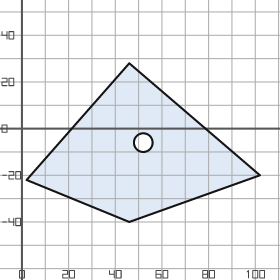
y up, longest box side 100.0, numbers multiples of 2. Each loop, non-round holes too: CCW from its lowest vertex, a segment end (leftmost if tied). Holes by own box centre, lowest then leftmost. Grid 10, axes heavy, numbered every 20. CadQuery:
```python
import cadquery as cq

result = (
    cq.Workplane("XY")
    .moveTo(46.0, -40.0)
    .lineTo(102.0, -20.0)
    .lineTo(46.0, 28.0)
    .lineTo(2.0, -22.0)
    .close()
    .moveTo(52.0, -6.0)
    .circle(4.0)
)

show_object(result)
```